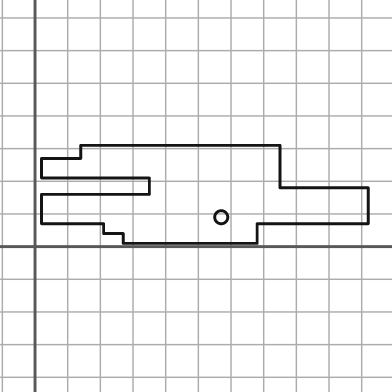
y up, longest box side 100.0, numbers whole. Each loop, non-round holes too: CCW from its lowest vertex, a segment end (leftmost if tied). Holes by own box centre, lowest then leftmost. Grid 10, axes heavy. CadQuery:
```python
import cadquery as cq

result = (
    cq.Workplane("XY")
    .moveTo(27.0, 1.0)
    .lineTo(68.0, 1.0)
    .lineTo(68.0, 7.0)
    .lineTo(102.0, 7.0)
    .lineTo(102.0, 18.0)
    .lineTo(75.0, 18.0)
    .lineTo(75.0, 31.0)
    .lineTo(14.0, 31.0)
    .lineTo(14.0, 27.0)
    .lineTo(2.0, 27.0)
    .lineTo(2.0, 21.0)
    .lineTo(35.0, 21.0)
    .lineTo(35.0, 16.0)
    .lineTo(2.0, 16.0)
    .lineTo(2.0, 7.0)
    .lineTo(21.0, 7.0)
    .lineTo(21.0, 4.0)
    .lineTo(27.0, 4.0)
    .close()
    .moveTo(57.0, 9.0)
    .circle(2.0)
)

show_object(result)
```